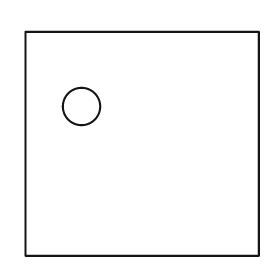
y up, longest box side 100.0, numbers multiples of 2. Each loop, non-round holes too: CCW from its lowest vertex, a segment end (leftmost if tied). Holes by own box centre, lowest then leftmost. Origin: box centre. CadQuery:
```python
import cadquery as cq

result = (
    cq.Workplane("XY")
    .moveTo(-50.0, -48.0)
    .lineTo(50.0, -48.0)
    .lineTo(50.0, 48.0)
    .lineTo(-50.0, 48.0)
    .close()
    .moveTo(-26.0, 16.0)
    .circle(8.0)
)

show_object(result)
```